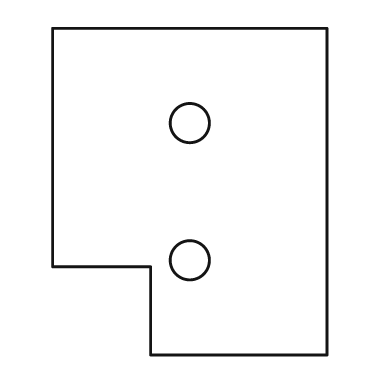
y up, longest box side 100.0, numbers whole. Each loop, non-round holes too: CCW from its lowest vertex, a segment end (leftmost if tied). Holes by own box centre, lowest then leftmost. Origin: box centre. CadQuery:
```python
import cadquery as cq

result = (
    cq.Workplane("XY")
    .moveTo(-12.0, -50.0)
    .lineTo(42.0, -50.0)
    .lineTo(42.0, 50.0)
    .lineTo(-42.0, 50.0)
    .lineTo(-42.0, -23.0)
    .lineTo(-12.0, -23.0)
    .close()
    .moveTo(0.0, -21.0)
    .circle(6.0)
    .moveTo(0.0, 21.0)
    .circle(6.0)
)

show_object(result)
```